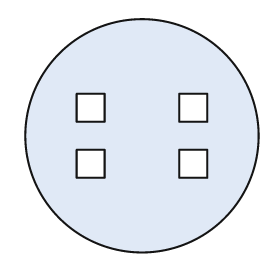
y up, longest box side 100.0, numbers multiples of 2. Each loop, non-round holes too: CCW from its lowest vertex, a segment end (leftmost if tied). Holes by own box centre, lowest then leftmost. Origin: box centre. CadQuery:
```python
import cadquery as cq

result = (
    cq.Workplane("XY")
    .moveTo(0.0, 0.0)
    .circle(50.0)
    .moveTo(-28.0, -18.0)
    .lineTo(-16.0, -18.0)
    .lineTo(-16.0, -6.0)
    .lineTo(-28.0, -6.0)
    .close()
    .moveTo(16.0, -18.0)
    .lineTo(28.0, -18.0)
    .lineTo(28.0, -6.0)
    .lineTo(16.0, -6.0)
    .close()
    .moveTo(-28.0, 6.0)
    .lineTo(-16.0, 6.0)
    .lineTo(-16.0, 18.0)
    .lineTo(-28.0, 18.0)
    .close()
    .moveTo(16.0, 6.0)
    .lineTo(28.0, 6.0)
    .lineTo(28.0, 18.0)
    .lineTo(16.0, 18.0)
    .close()
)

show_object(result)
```